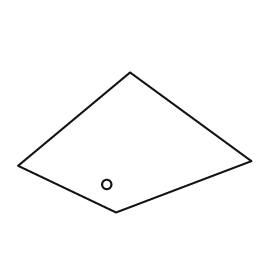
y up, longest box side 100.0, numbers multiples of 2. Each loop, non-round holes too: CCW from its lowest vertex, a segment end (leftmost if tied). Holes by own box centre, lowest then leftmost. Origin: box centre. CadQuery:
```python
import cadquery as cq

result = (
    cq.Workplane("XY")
    .moveTo(-8.0, -30.0)
    .lineTo(50.0, -8.0)
    .lineTo(-2.0, 30.0)
    .lineTo(-50.0, -10.0)
    .close()
    .moveTo(-12.0, -18.0)
    .circle(2.0)
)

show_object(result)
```